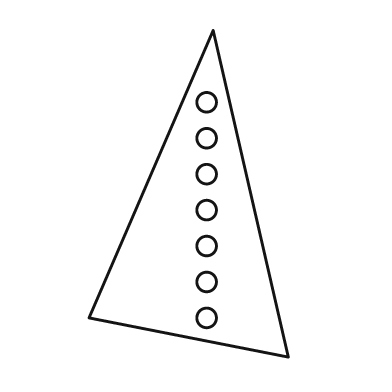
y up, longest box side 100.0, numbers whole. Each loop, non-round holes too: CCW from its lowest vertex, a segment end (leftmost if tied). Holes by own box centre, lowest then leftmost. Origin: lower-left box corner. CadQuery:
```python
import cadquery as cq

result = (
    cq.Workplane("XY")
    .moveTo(61.0, 0.0)
    .lineTo(38.0, 100.0)
    .lineTo(0.0, 12.0)
    .close()
    .moveTo(36.0, 12.0)
    .circle(3.0)
    .moveTo(36.0, 23.0)
    .circle(3.0)
    .moveTo(36.0, 34.0)
    .circle(3.0)
    .moveTo(36.0, 45.0)
    .circle(3.0)
    .moveTo(36.0, 56.0)
    .circle(3.0)
    .moveTo(36.0, 67.0)
    .circle(3.0)
    .moveTo(36.0, 78.0)
    .circle(3.0)
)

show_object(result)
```